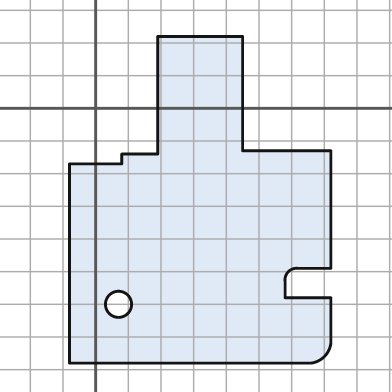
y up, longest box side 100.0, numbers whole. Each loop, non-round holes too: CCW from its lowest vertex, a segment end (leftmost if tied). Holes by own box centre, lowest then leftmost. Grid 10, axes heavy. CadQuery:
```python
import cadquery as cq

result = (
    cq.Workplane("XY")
    .moveTo(-8.0, -78.0)
    .lineTo(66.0, -78.0)
    .threePointArc((70.0, -76.0), (72.0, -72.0))
    .lineTo(72.0, -58.0)
    .lineTo(58.0, -58.0)
    .lineTo(58.0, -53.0)
    .threePointArc((59.0, -50.0), (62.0, -49.0))
    .lineTo(72.0, -49.0)
    .lineTo(72.0, -13.0)
    .lineTo(45.0, -13.0)
    .lineTo(45.0, 22.0)
    .lineTo(19.0, 22.0)
    .lineTo(19.0, -14.0)
    .lineTo(8.0, -14.0)
    .lineTo(8.0, -17.0)
    .lineTo(-8.0, -17.0)
    .close()
    .moveTo(7.0, -60.0)
    .circle(4.0)
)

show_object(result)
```